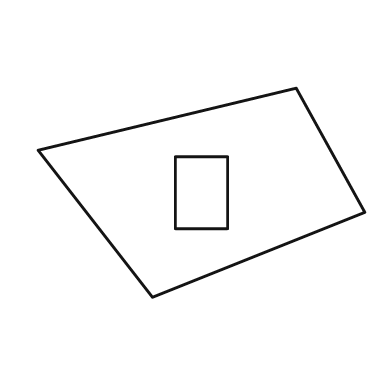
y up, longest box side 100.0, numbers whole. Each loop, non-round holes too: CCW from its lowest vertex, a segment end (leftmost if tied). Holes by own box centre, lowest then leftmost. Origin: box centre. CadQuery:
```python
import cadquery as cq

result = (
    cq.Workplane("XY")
    .moveTo(-15.0, -32.0)
    .lineTo(50.0, -6.0)
    .lineTo(29.0, 32.0)
    .lineTo(-50.0, 13.0)
    .close()
    .moveTo(-8.0, -11.0)
    .lineTo(8.0, -11.0)
    .lineTo(8.0, 11.0)
    .lineTo(-8.0, 11.0)
    .close()
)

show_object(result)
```